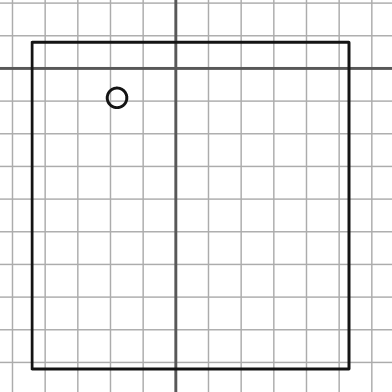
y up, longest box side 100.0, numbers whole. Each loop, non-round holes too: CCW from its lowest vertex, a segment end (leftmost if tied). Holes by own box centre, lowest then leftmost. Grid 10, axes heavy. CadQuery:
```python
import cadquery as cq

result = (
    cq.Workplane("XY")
    .moveTo(-44.0, -92.0)
    .lineTo(53.0, -92.0)
    .lineTo(53.0, 8.0)
    .lineTo(-44.0, 8.0)
    .close()
    .moveTo(-18.0, -9.0)
    .circle(3.0)
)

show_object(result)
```